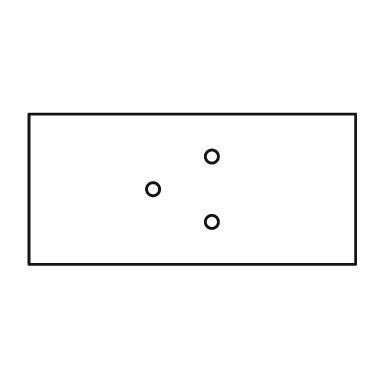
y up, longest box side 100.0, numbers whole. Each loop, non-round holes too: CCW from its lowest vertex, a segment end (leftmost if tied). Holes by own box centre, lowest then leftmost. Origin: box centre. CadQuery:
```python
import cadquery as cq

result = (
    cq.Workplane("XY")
    .moveTo(-50.0, -23.0)
    .lineTo(50.0, -23.0)
    .lineTo(50.0, 23.0)
    .lineTo(-50.0, 23.0)
    .close()
    .moveTo(6.0, -10.0)
    .circle(2.0)
    .moveTo(-12.0, 0.0)
    .circle(2.0)
    .moveTo(6.0, 10.0)
    .circle(2.0)
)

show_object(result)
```